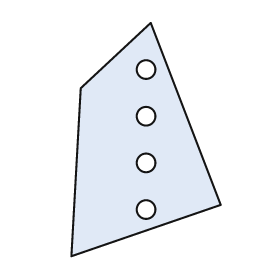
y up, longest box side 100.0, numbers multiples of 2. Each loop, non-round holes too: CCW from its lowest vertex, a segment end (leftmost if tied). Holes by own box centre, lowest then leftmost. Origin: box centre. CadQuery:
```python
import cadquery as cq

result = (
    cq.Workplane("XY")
    .moveTo(-32.0, -50.0)
    .lineTo(32.0, -28.0)
    .lineTo(2.0, 50.0)
    .lineTo(-28.0, 22.0)
    .close()
    .moveTo(0.0, -30.0)
    .circle(4.0)
    .moveTo(0.0, -10.0)
    .circle(4.0)
    .moveTo(0.0, 10.0)
    .circle(4.0)
    .moveTo(0.0, 30.0)
    .circle(4.0)
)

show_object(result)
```